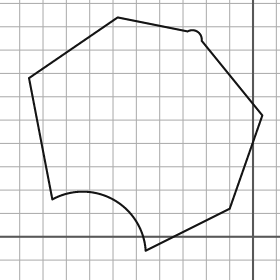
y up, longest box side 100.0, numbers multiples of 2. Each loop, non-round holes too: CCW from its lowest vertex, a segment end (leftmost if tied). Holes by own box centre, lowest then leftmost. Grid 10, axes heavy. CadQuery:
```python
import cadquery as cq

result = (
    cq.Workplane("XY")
    .moveTo(-46.0, -6.0)
    .lineTo(-10.0, 12.0)
    .lineTo(4.0, 52.0)
    .lineTo(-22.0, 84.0)
    .threePointArc((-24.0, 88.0), (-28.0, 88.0))
    .lineTo(-58.0, 94.0)
    .lineTo(-96.0, 68.0)
    .lineTo(-86.0, 16.0)
    .threePointArc((-60.0, 16.0), (-46.0, -6.0))
    .close()
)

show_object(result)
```